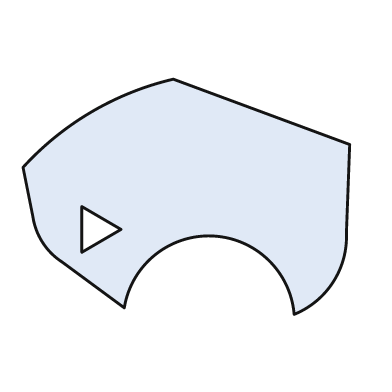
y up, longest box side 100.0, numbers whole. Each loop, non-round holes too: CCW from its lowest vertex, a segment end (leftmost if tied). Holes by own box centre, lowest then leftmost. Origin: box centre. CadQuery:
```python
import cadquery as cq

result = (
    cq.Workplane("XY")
    .moveTo(33.0, -36.0)
    .threePointArc((45.0, -26.0), (49.0, -11.0))
    .lineTo(50.0, 16.0)
    .lineTo(-4.0, 36.0)
    .threePointArc((-29.0, 26.0), (-50.0, 9.0))
    .lineTo(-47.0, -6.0)
    .threePointArc((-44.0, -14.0), (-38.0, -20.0))
    .lineTo(-19.0, -34.0)
    .threePointArc((8.0, -12.0), (33.0, -36.0))
    .close()
    .moveTo(-32.0, -17.0)
    .lineTo(-20.0, -10.0)
    .lineTo(-32.0, -3.0)
    .close()
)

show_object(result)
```